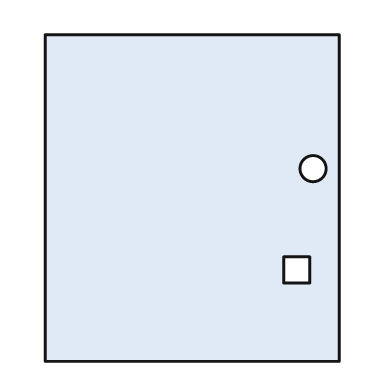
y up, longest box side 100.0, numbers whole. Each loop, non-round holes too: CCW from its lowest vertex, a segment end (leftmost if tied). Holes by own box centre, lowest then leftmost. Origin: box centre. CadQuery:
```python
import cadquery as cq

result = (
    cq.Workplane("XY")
    .moveTo(-45.0, -50.0)
    .lineTo(45.0, -50.0)
    .lineTo(45.0, 50.0)
    .lineTo(-45.0, 50.0)
    .close()
    .moveTo(28.0, -26.0)
    .lineTo(36.0, -26.0)
    .lineTo(36.0, -18.0)
    .lineTo(28.0, -18.0)
    .close()
    .moveTo(37.0, 9.0)
    .circle(4.0)
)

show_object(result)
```